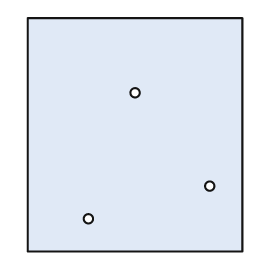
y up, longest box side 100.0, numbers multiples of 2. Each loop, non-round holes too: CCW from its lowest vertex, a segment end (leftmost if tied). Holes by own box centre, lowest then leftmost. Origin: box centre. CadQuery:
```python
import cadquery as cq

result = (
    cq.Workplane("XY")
    .moveTo(-46.0, -50.0)
    .lineTo(46.0, -50.0)
    .lineTo(46.0, 50.0)
    .lineTo(-46.0, 50.0)
    .close()
    .moveTo(-20.0, -36.0)
    .circle(2.0)
    .moveTo(32.0, -22.0)
    .circle(2.0)
    .moveTo(0.0, 18.0)
    .circle(2.0)
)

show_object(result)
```